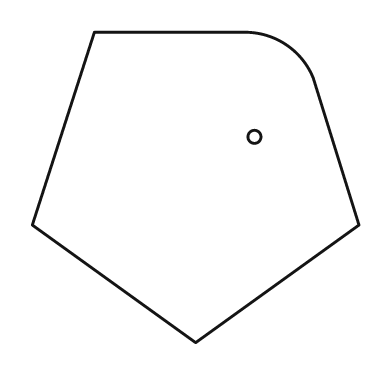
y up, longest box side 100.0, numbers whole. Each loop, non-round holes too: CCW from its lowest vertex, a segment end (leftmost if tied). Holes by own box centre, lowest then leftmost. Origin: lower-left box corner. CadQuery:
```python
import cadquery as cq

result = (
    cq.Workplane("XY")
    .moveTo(50.0, 0.0)
    .lineTo(100.0, 36.0)
    .lineTo(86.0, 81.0)
    .threePointArc((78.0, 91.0), (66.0, 95.0))
    .lineTo(19.0, 95.0)
    .lineTo(0.0, 36.0)
    .close()
    .moveTo(68.0, 63.0)
    .circle(2.0)
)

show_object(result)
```